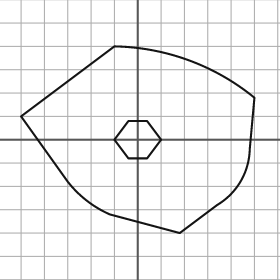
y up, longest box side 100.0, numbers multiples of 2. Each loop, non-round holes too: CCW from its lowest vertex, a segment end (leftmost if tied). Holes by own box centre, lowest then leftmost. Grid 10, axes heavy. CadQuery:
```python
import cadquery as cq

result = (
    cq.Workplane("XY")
    .moveTo(18.0, -40.0)
    .lineTo(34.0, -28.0)
    .threePointArc((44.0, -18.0), (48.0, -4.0))
    .lineTo(50.0, 18.0)
    .threePointArc((22.0, 34.0), (-10.0, 40.0))
    .lineTo(-50.0, 10.0)
    .lineTo(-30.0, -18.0)
    .threePointArc((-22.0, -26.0), (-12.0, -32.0))
    .close()
    .moveTo(-4.0, -8.0)
    .lineTo(4.0, -8.0)
    .lineTo(10.0, 0.0)
    .lineTo(4.0, 8.0)
    .lineTo(-4.0, 8.0)
    .lineTo(-10.0, 0.0)
    .close()
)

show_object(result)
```